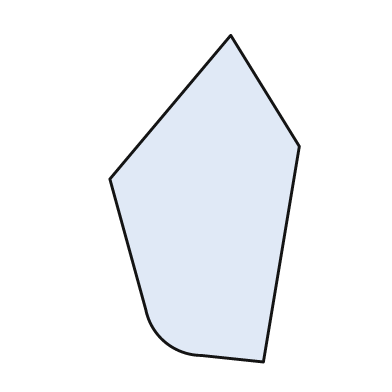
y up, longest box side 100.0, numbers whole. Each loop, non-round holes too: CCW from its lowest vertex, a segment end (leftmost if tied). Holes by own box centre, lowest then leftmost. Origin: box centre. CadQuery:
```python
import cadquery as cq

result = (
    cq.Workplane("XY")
    .moveTo(18.0, -50.0)
    .lineTo(29.0, 16.0)
    .lineTo(8.0, 50.0)
    .lineTo(-29.0, 6.0)
    .lineTo(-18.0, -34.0)
    .threePointArc((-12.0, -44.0), (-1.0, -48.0))
    .close()
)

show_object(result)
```